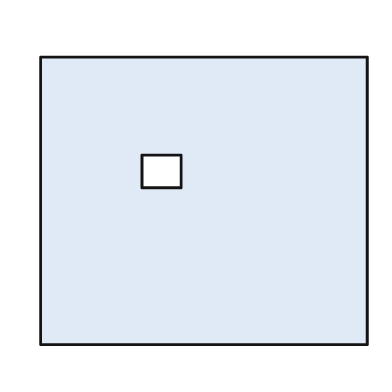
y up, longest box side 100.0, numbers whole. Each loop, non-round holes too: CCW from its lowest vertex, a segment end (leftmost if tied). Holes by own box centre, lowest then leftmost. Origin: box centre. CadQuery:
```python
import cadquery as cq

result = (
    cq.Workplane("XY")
    .moveTo(-50.0, -44.0)
    .lineTo(50.0, -44.0)
    .lineTo(50.0, 44.0)
    .lineTo(-50.0, 44.0)
    .close()
    .moveTo(-19.0, 4.0)
    .lineTo(-7.0, 4.0)
    .lineTo(-7.0, 14.0)
    .lineTo(-19.0, 14.0)
    .close()
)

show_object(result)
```